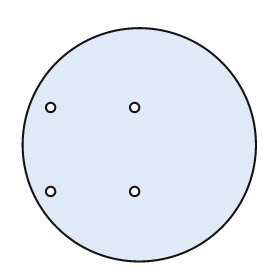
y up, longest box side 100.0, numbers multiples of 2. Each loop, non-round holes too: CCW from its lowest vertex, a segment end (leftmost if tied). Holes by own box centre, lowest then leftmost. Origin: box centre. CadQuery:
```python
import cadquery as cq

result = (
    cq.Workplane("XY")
    .moveTo(0.0, 0.0)
    .circle(50.0)
    .moveTo(-38.0, -20.0)
    .circle(2.0)
    .moveTo(-2.0, -20.0)
    .circle(2.0)
    .moveTo(-38.0, 16.0)
    .circle(2.0)
    .moveTo(-2.0, 16.0)
    .circle(2.0)
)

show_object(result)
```